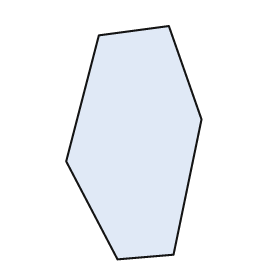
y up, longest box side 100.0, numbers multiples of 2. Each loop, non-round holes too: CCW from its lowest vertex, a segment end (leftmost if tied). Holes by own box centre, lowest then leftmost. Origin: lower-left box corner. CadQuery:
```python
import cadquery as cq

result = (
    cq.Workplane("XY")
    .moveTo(22.0, 0.0)
    .lineTo(46.0, 2.0)
    .lineTo(58.0, 60.0)
    .lineTo(44.0, 100.0)
    .lineTo(14.0, 96.0)
    .lineTo(0.0, 42.0)
    .close()
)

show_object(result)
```